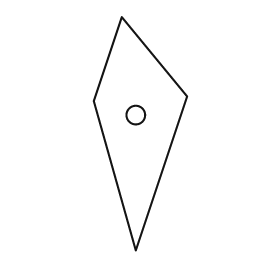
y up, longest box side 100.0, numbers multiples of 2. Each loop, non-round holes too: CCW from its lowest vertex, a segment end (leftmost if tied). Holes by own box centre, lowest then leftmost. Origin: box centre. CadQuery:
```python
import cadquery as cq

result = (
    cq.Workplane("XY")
    .moveTo(-2.0, -50.0)
    .lineTo(20.0, 16.0)
    .lineTo(-8.0, 50.0)
    .lineTo(-20.0, 14.0)
    .close()
    .moveTo(-2.0, 8.0)
    .circle(4.0)
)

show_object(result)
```